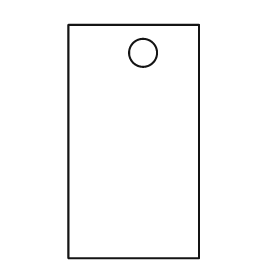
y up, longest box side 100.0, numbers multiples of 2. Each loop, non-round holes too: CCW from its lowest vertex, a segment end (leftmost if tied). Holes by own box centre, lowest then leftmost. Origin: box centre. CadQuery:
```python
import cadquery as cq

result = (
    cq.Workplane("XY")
    .moveTo(-28.0, -50.0)
    .lineTo(28.0, -50.0)
    .lineTo(28.0, 50.0)
    .lineTo(-28.0, 50.0)
    .close()
    .moveTo(4.0, 38.0)
    .circle(6.0)
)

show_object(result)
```